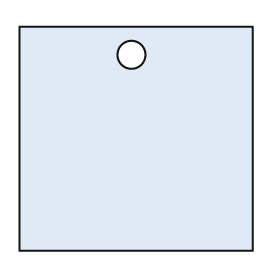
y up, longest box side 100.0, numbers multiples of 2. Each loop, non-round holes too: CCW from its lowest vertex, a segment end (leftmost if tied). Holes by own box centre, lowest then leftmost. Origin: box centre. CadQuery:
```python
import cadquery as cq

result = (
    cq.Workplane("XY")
    .moveTo(-50.0, -48.0)
    .lineTo(50.0, -48.0)
    .lineTo(50.0, 48.0)
    .lineTo(-50.0, 48.0)
    .close()
    .moveTo(-2.0, 36.0)
    .circle(6.0)
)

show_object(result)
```